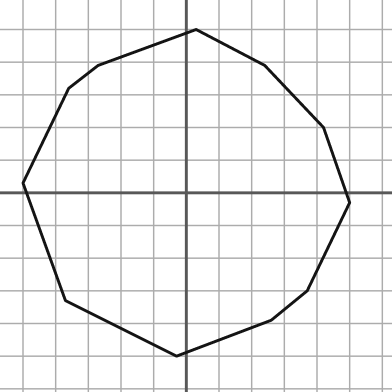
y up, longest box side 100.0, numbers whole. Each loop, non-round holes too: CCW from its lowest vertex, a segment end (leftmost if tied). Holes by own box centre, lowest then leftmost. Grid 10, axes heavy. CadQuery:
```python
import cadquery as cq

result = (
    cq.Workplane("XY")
    .moveTo(-3.0, -50.0)
    .lineTo(26.0, -39.0)
    .lineTo(37.0, -30.0)
    .lineTo(50.0, -3.0)
    .lineTo(42.0, 20.0)
    .lineTo(24.0, 39.0)
    .lineTo(3.0, 50.0)
    .lineTo(-27.0, 39.0)
    .lineTo(-36.0, 32.0)
    .lineTo(-50.0, 3.0)
    .lineTo(-37.0, -33.0)
    .close()
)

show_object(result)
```